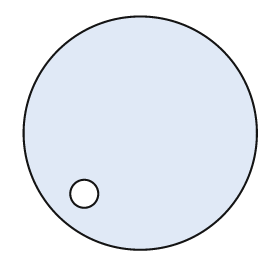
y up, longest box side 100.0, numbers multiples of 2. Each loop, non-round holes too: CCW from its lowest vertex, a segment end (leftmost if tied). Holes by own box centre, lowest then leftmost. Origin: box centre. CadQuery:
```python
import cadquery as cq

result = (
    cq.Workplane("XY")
    .moveTo(0.0, 0.0)
    .circle(50.0)
    .moveTo(-24.0, -26.0)
    .circle(6.0)
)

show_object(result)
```